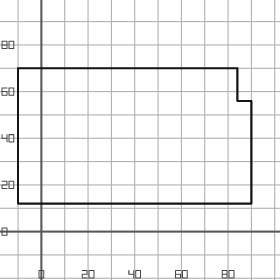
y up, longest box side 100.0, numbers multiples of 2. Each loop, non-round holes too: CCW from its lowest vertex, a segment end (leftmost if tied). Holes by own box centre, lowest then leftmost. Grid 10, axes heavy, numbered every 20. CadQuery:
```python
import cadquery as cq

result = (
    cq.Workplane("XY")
    .moveTo(-10.0, 12.0)
    .lineTo(90.0, 12.0)
    .lineTo(90.0, 56.0)
    .lineTo(84.0, 56.0)
    .lineTo(84.0, 70.0)
    .lineTo(-10.0, 70.0)
    .close()
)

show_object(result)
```